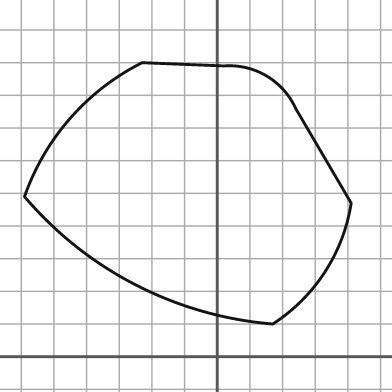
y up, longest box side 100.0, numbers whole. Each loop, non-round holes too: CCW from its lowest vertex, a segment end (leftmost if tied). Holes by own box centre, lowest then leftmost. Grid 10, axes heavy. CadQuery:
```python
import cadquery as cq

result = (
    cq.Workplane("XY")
    .moveTo(17.0, 10.0)
    .threePointArc((33.0, 26.0), (41.0, 47.0))
    .lineTo(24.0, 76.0)
    .threePointArc((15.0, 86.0), (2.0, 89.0))
    .lineTo(-23.0, 90.0)
    .threePointArc((-45.0, 73.0), (-59.0, 49.0))
    .threePointArc((-25.0, 22.0), (17.0, 10.0))
    .close()
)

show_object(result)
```